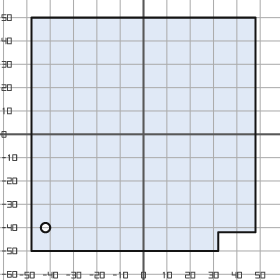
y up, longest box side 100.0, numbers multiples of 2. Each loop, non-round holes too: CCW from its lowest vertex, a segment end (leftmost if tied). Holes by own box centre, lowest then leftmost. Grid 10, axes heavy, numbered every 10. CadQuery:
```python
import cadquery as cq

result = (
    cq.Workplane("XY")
    .moveTo(-48.0, -50.0)
    .lineTo(32.0, -50.0)
    .lineTo(32.0, -42.0)
    .lineTo(48.0, -42.0)
    .lineTo(48.0, 50.0)
    .lineTo(-48.0, 50.0)
    .close()
    .moveTo(-42.0, -40.0)
    .circle(2.0)
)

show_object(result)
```